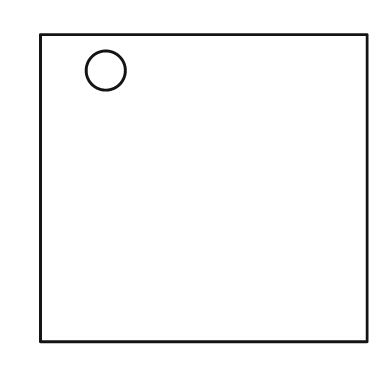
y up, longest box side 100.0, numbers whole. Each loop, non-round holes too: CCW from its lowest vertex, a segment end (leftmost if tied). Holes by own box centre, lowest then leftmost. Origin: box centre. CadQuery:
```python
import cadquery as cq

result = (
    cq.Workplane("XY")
    .moveTo(-50.0, -47.0)
    .lineTo(50.0, -47.0)
    .lineTo(50.0, 47.0)
    .lineTo(-50.0, 47.0)
    .close()
    .moveTo(-30.0, 36.0)
    .circle(6.0)
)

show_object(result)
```